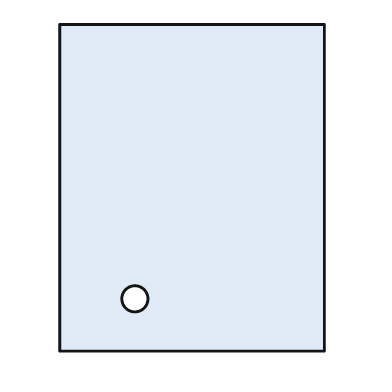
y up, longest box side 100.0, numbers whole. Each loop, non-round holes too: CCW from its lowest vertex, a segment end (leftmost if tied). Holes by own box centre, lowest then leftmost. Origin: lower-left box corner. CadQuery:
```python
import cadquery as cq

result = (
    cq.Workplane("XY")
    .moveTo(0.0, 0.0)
    .lineTo(81.0, 0.0)
    .lineTo(81.0, 100.0)
    .lineTo(0.0, 100.0)
    .close()
    .moveTo(23.0, 16.0)
    .circle(4.0)
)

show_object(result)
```